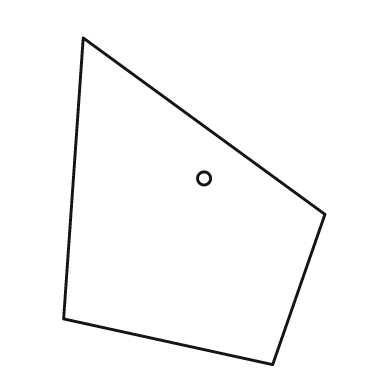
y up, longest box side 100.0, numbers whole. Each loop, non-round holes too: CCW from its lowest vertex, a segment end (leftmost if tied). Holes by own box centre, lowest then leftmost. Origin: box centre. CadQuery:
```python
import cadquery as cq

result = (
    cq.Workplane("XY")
    .moveTo(24.0, -50.0)
    .lineTo(40.0, -4.0)
    .lineTo(-34.0, 50.0)
    .lineTo(-40.0, -36.0)
    .close()
    .moveTo(3.0, 7.0)
    .circle(2.0)
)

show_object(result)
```